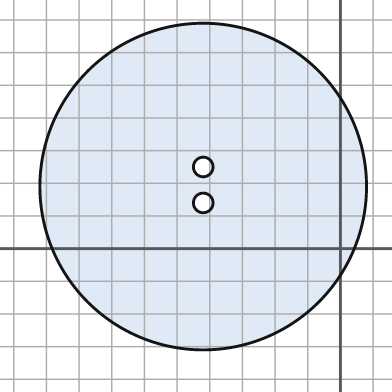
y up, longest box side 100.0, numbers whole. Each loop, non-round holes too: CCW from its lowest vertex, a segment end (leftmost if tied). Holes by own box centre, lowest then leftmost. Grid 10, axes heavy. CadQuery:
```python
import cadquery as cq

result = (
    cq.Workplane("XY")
    .moveTo(-42.0, 19.0)
    .circle(50.0)
    .moveTo(-42.0, 14.0)
    .circle(3.0)
    .moveTo(-42.0, 25.0)
    .circle(3.0)
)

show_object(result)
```